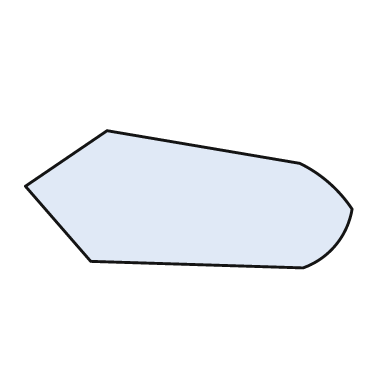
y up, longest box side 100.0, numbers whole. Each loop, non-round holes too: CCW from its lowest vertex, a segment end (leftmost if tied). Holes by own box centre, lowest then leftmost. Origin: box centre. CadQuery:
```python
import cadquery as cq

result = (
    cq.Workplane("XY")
    .moveTo(35.0, -21.0)
    .threePointArc((45.0, -14.0), (50.0, -3.0))
    .threePointArc((43.0, 5.0), (34.0, 11.0))
    .lineTo(-25.0, 21.0)
    .lineTo(-50.0, 4.0)
    .lineTo(-30.0, -19.0)
    .close()
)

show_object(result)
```